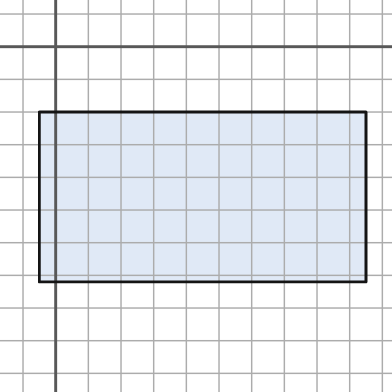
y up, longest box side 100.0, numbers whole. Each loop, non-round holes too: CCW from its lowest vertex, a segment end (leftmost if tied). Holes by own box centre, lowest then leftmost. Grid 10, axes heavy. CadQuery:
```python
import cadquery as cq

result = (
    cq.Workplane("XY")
    .moveTo(-5.0, -72.0)
    .lineTo(95.0, -72.0)
    .lineTo(95.0, -20.0)
    .lineTo(-5.0, -20.0)
    .close()
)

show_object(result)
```